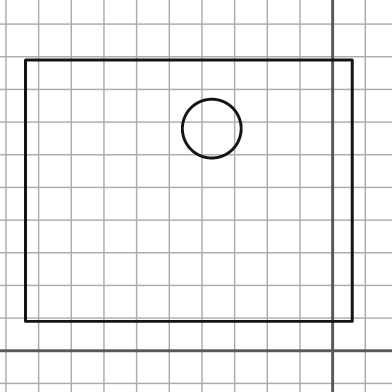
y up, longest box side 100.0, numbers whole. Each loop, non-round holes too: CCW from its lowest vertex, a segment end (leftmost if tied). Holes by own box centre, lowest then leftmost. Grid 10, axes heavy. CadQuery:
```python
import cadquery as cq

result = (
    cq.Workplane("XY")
    .moveTo(-94.0, 9.0)
    .lineTo(6.0, 9.0)
    .lineTo(6.0, 89.0)
    .lineTo(-94.0, 89.0)
    .close()
    .moveTo(-37.0, 68.0)
    .circle(9.0)
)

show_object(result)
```